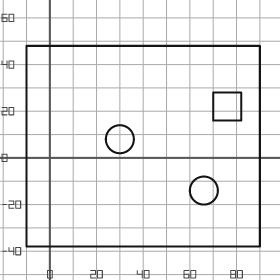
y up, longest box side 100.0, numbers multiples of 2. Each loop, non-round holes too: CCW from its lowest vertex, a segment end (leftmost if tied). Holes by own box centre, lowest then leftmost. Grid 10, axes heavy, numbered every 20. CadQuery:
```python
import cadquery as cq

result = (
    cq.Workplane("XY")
    .moveTo(-10.0, -38.0)
    .lineTo(90.0, -38.0)
    .lineTo(90.0, 48.0)
    .lineTo(-10.0, 48.0)
    .close()
    .moveTo(66.0, -14.0)
    .circle(6.0)
    .moveTo(30.0, 8.0)
    .circle(6.0)
    .moveTo(70.0, 16.0)
    .lineTo(82.0, 16.0)
    .lineTo(82.0, 28.0)
    .lineTo(70.0, 28.0)
    .close()
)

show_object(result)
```